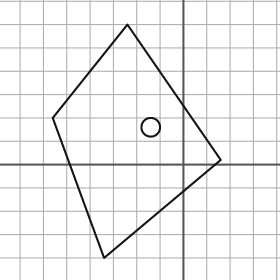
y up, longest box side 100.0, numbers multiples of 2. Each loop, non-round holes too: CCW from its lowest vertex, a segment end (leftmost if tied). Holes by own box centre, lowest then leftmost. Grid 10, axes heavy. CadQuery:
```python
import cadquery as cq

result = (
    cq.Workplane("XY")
    .moveTo(-34.0, -40.0)
    .lineTo(16.0, 2.0)
    .lineTo(-24.0, 60.0)
    .lineTo(-56.0, 20.0)
    .close()
    .moveTo(-14.0, 16.0)
    .circle(4.0)
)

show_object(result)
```